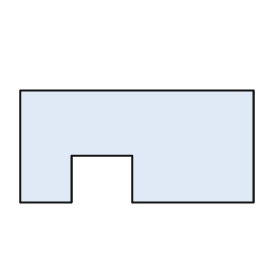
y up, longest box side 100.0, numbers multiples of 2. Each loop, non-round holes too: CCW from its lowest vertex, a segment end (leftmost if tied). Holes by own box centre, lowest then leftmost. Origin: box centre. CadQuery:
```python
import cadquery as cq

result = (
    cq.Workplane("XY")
    .moveTo(-50.0, -24.0)
    .lineTo(-28.0, -24.0)
    .lineTo(-28.0, -4.0)
    .lineTo(-2.0, -4.0)
    .lineTo(-2.0, -24.0)
    .lineTo(50.0, -24.0)
    .lineTo(50.0, 24.0)
    .lineTo(-50.0, 24.0)
    .close()
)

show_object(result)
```